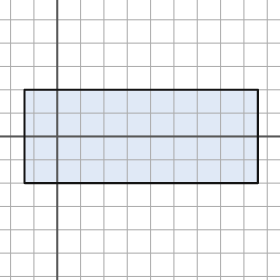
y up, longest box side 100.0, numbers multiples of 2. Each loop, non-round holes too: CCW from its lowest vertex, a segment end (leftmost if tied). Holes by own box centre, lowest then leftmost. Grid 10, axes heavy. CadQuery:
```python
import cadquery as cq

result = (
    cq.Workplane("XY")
    .moveTo(-14.0, -20.0)
    .lineTo(86.0, -20.0)
    .lineTo(86.0, 20.0)
    .lineTo(-14.0, 20.0)
    .close()
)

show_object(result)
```